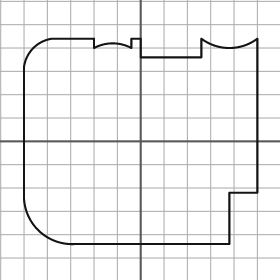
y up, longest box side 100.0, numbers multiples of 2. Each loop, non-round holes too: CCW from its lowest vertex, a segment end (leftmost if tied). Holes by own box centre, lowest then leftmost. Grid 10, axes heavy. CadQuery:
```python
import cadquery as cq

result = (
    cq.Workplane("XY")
    .moveTo(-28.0, -44.0)
    .lineTo(38.0, -44.0)
    .lineTo(38.0, -22.0)
    .lineTo(50.0, -22.0)
    .lineTo(50.0, 44.0)
    .threePointArc((38.0, 40.0), (26.0, 44.0))
    .lineTo(26.0, 36.0)
    .lineTo(0.0, 36.0)
    .lineTo(0.0, 44.0)
    .lineTo(-4.0, 44.0)
    .lineTo(-4.0, 40.0)
    .threePointArc((-12.0, 42.0), (-20.0, 40.0))
    .lineTo(-20.0, 44.0)
    .lineTo(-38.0, 44.0)
    .threePointArc((-46.0, 40.0), (-50.0, 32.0))
    .lineTo(-50.0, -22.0)
    .threePointArc((-44.0, -38.0), (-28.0, -44.0))
    .close()
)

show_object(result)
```